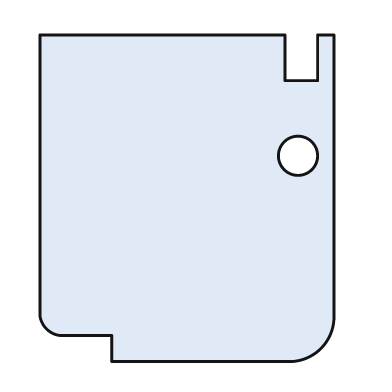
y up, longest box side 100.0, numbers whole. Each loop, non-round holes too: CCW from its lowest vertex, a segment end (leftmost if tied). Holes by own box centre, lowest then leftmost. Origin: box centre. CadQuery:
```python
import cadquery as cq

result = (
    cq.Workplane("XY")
    .moveTo(-23.0, -50.0)
    .lineTo(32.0, -50.0)
    .threePointArc((41.0, -46.0), (45.0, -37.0))
    .lineTo(45.0, 50.0)
    .lineTo(40.0, 50.0)
    .lineTo(40.0, 36.0)
    .lineTo(30.0, 36.0)
    .lineTo(30.0, 50.0)
    .lineTo(-45.0, 50.0)
    .lineTo(-45.0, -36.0)
    .threePointArc((-43.0, -40.0), (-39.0, -42.0))
    .lineTo(-23.0, -42.0)
    .close()
    .moveTo(34.0, 13.0)
    .circle(6.0)
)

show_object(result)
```